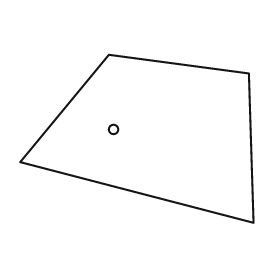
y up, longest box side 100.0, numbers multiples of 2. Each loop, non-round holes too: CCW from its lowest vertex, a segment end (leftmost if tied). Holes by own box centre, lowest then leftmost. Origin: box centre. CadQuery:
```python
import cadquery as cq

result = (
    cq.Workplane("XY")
    .moveTo(50.0, -36.0)
    .lineTo(48.0, 28.0)
    .lineTo(-12.0, 36.0)
    .lineTo(-50.0, -10.0)
    .close()
    .moveTo(-10.0, 4.0)
    .circle(2.0)
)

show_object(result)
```